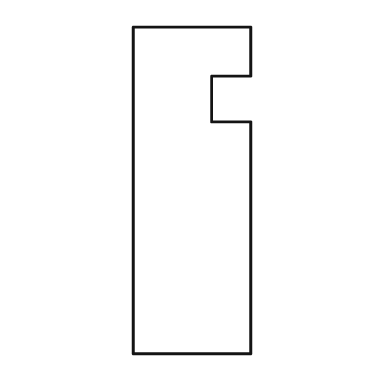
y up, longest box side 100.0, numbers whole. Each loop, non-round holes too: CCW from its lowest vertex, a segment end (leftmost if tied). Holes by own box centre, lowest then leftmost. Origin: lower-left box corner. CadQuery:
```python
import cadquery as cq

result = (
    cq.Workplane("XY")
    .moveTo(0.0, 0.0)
    .lineTo(36.0, 0.0)
    .lineTo(36.0, 71.0)
    .lineTo(24.0, 71.0)
    .lineTo(24.0, 85.0)
    .lineTo(36.0, 85.0)
    .lineTo(36.0, 100.0)
    .lineTo(0.0, 100.0)
    .close()
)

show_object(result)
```